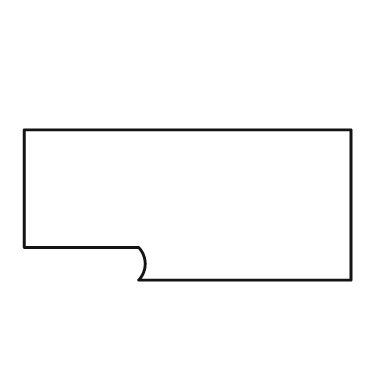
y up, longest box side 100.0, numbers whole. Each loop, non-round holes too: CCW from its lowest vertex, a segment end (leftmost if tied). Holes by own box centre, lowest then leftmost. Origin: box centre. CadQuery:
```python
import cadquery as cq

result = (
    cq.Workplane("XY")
    .moveTo(-15.0, -23.0)
    .lineTo(50.0, -23.0)
    .lineTo(50.0, 23.0)
    .lineTo(-50.0, 23.0)
    .lineTo(-50.0, -13.0)
    .lineTo(-15.0, -13.0)
    .threePointArc((-13.0, -18.0), (-15.0, -23.0))
    .close()
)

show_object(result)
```